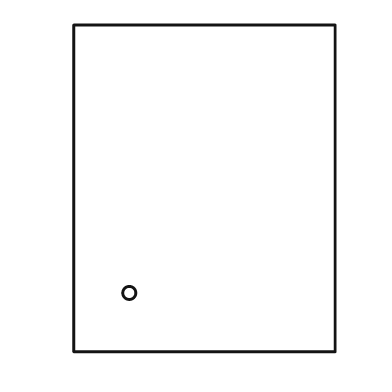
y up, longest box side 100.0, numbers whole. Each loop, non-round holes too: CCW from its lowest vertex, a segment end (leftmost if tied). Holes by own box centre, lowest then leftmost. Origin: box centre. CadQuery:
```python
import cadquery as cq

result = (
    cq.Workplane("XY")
    .moveTo(-40.0, -50.0)
    .lineTo(40.0, -50.0)
    .lineTo(40.0, 50.0)
    .lineTo(-40.0, 50.0)
    .close()
    .moveTo(-23.0, -32.0)
    .circle(2.0)
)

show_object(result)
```